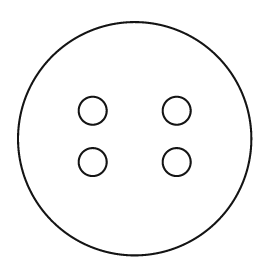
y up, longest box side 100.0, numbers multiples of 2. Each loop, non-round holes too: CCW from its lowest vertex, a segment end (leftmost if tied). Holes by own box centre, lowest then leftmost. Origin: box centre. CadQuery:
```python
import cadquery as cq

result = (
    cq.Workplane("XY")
    .moveTo(0.0, 0.0)
    .circle(50.0)
    .moveTo(-18.0, -10.0)
    .circle(6.0)
    .moveTo(18.0, -10.0)
    .circle(6.0)
    .moveTo(-18.0, 12.0)
    .circle(6.0)
    .moveTo(18.0, 12.0)
    .circle(6.0)
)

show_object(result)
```